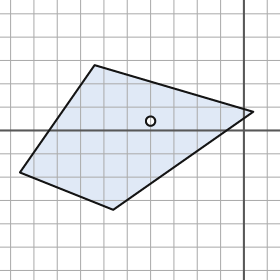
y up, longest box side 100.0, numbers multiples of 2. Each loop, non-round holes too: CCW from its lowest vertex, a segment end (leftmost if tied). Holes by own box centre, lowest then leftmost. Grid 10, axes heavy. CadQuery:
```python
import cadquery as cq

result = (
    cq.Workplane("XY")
    .moveTo(-56.0, -34.0)
    .lineTo(4.0, 8.0)
    .lineTo(-64.0, 28.0)
    .lineTo(-96.0, -18.0)
    .close()
    .moveTo(-40.0, 4.0)
    .circle(2.0)
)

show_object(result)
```